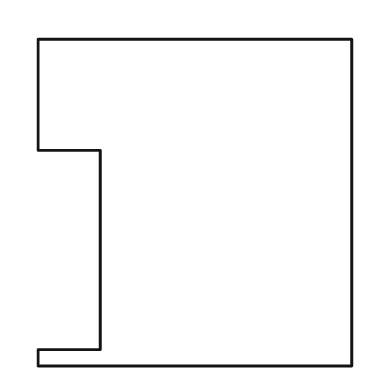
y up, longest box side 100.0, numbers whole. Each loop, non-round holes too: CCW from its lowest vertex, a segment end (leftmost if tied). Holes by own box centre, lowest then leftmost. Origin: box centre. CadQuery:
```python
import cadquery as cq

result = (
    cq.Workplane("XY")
    .moveTo(-48.0, -50.0)
    .lineTo(48.0, -50.0)
    .lineTo(48.0, 50.0)
    .lineTo(-48.0, 50.0)
    .lineTo(-48.0, 16.0)
    .lineTo(-29.0, 16.0)
    .lineTo(-29.0, -45.0)
    .lineTo(-48.0, -45.0)
    .close()
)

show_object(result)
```